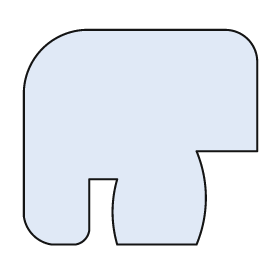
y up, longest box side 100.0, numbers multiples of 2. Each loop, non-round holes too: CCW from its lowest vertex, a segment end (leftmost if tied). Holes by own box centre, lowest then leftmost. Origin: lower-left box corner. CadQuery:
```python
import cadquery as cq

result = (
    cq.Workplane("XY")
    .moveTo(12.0, 0.0)
    .lineTo(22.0, 0.0)
    .threePointArc((26.0, 2.0), (28.0, 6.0))
    .lineTo(28.0, 28.0)
    .lineTo(40.0, 28.0)
    .threePointArc((38.0, 14.0), (40.0, 0.0))
    .lineTo(74.0, 0.0)
    .threePointArc((78.0, 20.0), (74.0, 40.0))
    .lineTo(100.0, 40.0)
    .lineTo(100.0, 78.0)
    .threePointArc((96.0, 88.0), (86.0, 92.0))
    .lineTo(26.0, 92.0)
    .threePointArc((8.0, 84.0), (0.0, 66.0))
    .lineTo(0.0, 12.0)
    .threePointArc((4.0, 4.0), (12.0, 0.0))
    .close()
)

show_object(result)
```